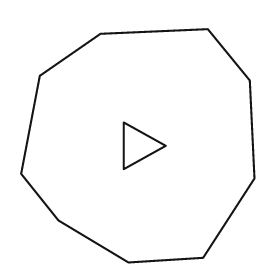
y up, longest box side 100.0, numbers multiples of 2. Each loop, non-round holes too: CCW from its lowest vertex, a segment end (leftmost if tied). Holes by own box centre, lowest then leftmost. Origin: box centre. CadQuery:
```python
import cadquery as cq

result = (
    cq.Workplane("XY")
    .moveTo(-4.0, -50.0)
    .lineTo(28.0, -48.0)
    .lineTo(50.0, -14.0)
    .lineTo(48.0, 28.0)
    .lineTo(30.0, 50.0)
    .lineTo(-16.0, 48.0)
    .lineTo(-42.0, 30.0)
    .lineTo(-50.0, -12.0)
    .lineTo(-34.0, -32.0)
    .close()
    .moveTo(-6.0, -10.0)
    .lineTo(12.0, 0.0)
    .lineTo(-6.0, 10.0)
    .close()
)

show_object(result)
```